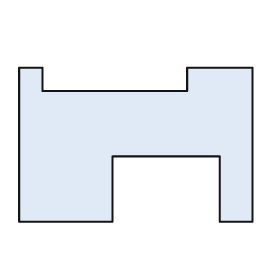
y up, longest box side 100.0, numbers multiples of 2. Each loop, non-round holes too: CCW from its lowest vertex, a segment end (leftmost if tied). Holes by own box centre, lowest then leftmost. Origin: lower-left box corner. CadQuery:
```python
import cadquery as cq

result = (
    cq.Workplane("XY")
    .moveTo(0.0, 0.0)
    .lineTo(40.0, 0.0)
    .lineTo(40.0, 28.0)
    .lineTo(86.0, 28.0)
    .lineTo(86.0, 0.0)
    .lineTo(100.0, 0.0)
    .lineTo(100.0, 66.0)
    .lineTo(72.0, 66.0)
    .lineTo(72.0, 56.0)
    .lineTo(10.0, 56.0)
    .lineTo(10.0, 66.0)
    .lineTo(0.0, 66.0)
    .close()
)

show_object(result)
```